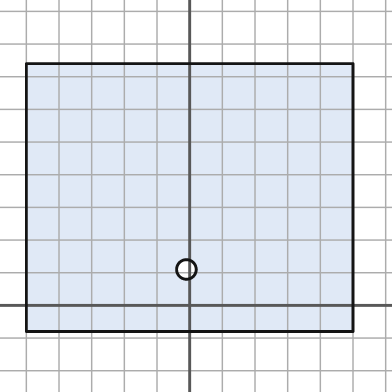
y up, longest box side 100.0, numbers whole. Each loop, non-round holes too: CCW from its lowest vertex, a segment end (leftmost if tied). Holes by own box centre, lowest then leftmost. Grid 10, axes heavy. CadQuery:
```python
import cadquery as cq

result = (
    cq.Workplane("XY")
    .moveTo(-50.0, -8.0)
    .lineTo(50.0, -8.0)
    .lineTo(50.0, 74.0)
    .lineTo(-50.0, 74.0)
    .close()
    .moveTo(-1.0, 11.0)
    .circle(3.0)
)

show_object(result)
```